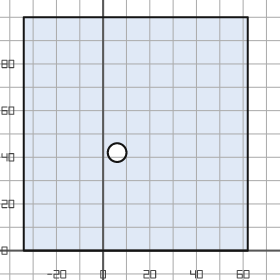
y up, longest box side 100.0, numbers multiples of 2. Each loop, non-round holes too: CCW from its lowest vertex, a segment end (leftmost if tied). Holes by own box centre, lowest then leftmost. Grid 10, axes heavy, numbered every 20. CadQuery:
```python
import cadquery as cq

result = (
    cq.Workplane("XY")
    .moveTo(-34.0, 0.0)
    .lineTo(62.0, 0.0)
    .lineTo(62.0, 100.0)
    .lineTo(-34.0, 100.0)
    .close()
    .moveTo(6.0, 42.0)
    .circle(4.0)
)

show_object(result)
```